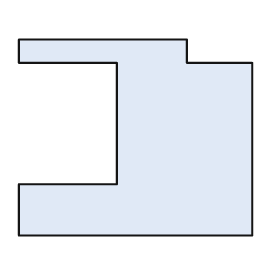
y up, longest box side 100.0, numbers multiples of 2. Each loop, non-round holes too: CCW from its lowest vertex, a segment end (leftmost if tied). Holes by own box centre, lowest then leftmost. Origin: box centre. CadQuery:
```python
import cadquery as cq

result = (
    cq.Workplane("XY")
    .moveTo(-50.0, -42.0)
    .lineTo(50.0, -42.0)
    .lineTo(50.0, 32.0)
    .lineTo(22.0, 32.0)
    .lineTo(22.0, 42.0)
    .lineTo(-50.0, 42.0)
    .lineTo(-50.0, 32.0)
    .lineTo(-8.0, 32.0)
    .lineTo(-8.0, -20.0)
    .lineTo(-50.0, -20.0)
    .close()
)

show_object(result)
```